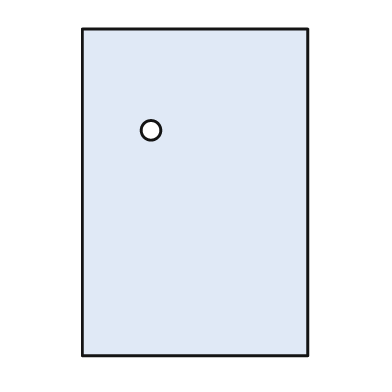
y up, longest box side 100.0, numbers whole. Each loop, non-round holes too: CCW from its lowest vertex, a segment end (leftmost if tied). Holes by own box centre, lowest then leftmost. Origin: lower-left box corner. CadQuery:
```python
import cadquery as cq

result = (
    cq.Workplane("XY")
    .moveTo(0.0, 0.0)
    .lineTo(69.0, 0.0)
    .lineTo(69.0, 100.0)
    .lineTo(0.0, 100.0)
    .close()
    .moveTo(21.0, 69.0)
    .circle(3.0)
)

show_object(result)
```